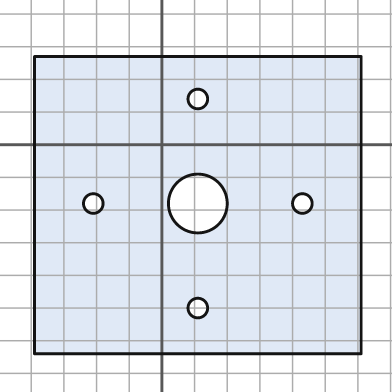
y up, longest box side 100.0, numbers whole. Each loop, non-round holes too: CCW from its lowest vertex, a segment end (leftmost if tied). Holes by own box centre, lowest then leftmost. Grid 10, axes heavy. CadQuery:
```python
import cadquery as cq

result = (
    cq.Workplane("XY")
    .moveTo(-39.0, -64.0)
    .lineTo(61.0, -64.0)
    .lineTo(61.0, 27.0)
    .lineTo(-39.0, 27.0)
    .close()
    .moveTo(11.0, -50.0)
    .circle(3.0)
    .moveTo(-21.0, -18.0)
    .circle(3.0)
    .moveTo(11.0, -18.0)
    .circle(9.0)
    .moveTo(43.0, -18.0)
    .circle(3.0)
    .moveTo(11.0, 14.0)
    .circle(3.0)
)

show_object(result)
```